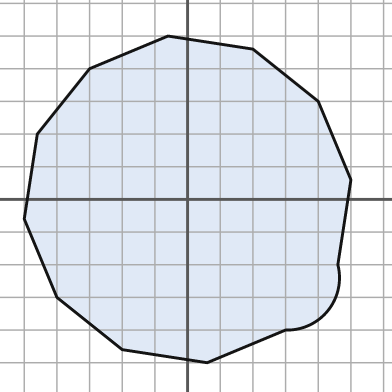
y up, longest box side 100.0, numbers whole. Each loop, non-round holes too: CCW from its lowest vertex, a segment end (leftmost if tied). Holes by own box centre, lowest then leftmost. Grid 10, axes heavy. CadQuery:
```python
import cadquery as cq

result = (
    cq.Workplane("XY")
    .moveTo(6.0, -50.0)
    .lineTo(30.0, -40.0)
    .threePointArc((43.0, -34.0), (46.0, -20.0))
    .lineTo(50.0, 6.0)
    .lineTo(40.0, 30.0)
    .lineTo(20.0, 46.0)
    .lineTo(-6.0, 50.0)
    .lineTo(-30.0, 40.0)
    .lineTo(-46.0, 20.0)
    .lineTo(-50.0, -6.0)
    .lineTo(-40.0, -30.0)
    .lineTo(-20.0, -46.0)
    .close()
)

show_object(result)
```